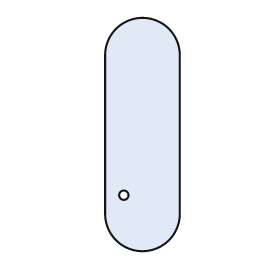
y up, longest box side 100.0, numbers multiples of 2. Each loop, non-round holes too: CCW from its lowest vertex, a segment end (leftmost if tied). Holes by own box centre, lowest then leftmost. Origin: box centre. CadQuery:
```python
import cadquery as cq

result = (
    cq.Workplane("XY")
    .moveTo(-16.0, -34.0)
    .threePointArc((0.0, -50.0), (16.0, -34.0))
    .lineTo(16.0, 34.0)
    .threePointArc((0.0, 50.0), (-16.0, 34.0))
    .close()
    .moveTo(-8.0, -26.0)
    .circle(2.0)
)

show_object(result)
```